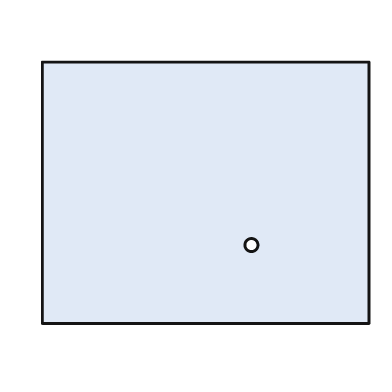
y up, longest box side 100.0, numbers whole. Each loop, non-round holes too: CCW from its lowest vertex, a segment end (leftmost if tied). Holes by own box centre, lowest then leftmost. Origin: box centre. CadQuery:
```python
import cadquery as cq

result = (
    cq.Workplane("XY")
    .moveTo(-50.0, -40.0)
    .lineTo(50.0, -40.0)
    .lineTo(50.0, 40.0)
    .lineTo(-50.0, 40.0)
    .close()
    .moveTo(14.0, -16.0)
    .circle(2.0)
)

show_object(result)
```